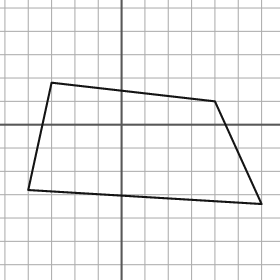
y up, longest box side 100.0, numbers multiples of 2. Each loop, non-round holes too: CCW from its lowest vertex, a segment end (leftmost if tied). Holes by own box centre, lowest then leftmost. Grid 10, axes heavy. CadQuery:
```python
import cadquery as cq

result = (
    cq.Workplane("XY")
    .moveTo(60.0, -34.0)
    .lineTo(40.0, 10.0)
    .lineTo(-30.0, 18.0)
    .lineTo(-40.0, -28.0)
    .close()
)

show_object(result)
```